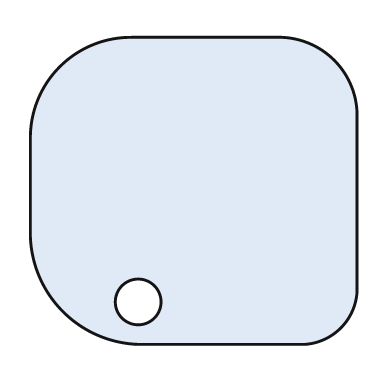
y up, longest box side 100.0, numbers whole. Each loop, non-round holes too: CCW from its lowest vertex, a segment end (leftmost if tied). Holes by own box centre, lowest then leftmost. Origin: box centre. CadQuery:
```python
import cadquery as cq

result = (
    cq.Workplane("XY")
    .moveTo(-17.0, -47.0)
    .lineTo(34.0, -47.0)
    .threePointArc((45.0, -42.0), (50.0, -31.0))
    .lineTo(50.0, 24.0)
    .threePointArc((43.0, 40.0), (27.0, 47.0))
    .lineTo(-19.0, 47.0)
    .threePointArc((-41.0, 38.0), (-50.0, 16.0))
    .lineTo(-50.0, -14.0)
    .threePointArc((-40.0, -37.0), (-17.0, -47.0))
    .close()
    .moveTo(-17.0, -34.0)
    .circle(7.0)
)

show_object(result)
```